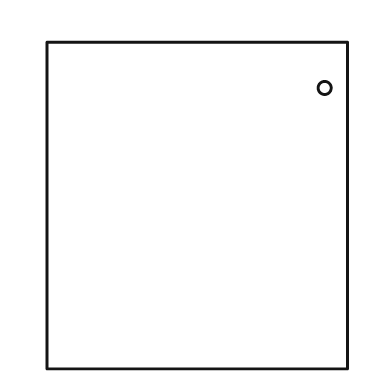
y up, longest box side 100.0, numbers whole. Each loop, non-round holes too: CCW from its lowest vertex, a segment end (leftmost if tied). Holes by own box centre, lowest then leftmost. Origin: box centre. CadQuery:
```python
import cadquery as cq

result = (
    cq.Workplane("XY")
    .moveTo(-46.0, -50.0)
    .lineTo(46.0, -50.0)
    .lineTo(46.0, 50.0)
    .lineTo(-46.0, 50.0)
    .close()
    .moveTo(39.0, 36.0)
    .circle(2.0)
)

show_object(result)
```